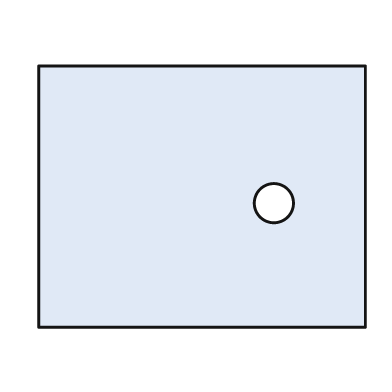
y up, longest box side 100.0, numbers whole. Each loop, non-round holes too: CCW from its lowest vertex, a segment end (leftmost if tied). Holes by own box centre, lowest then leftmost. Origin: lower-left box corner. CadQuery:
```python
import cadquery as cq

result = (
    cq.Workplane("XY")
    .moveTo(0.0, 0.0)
    .lineTo(100.0, 0.0)
    .lineTo(100.0, 80.0)
    .lineTo(0.0, 80.0)
    .close()
    .moveTo(72.0, 38.0)
    .circle(6.0)
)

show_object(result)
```